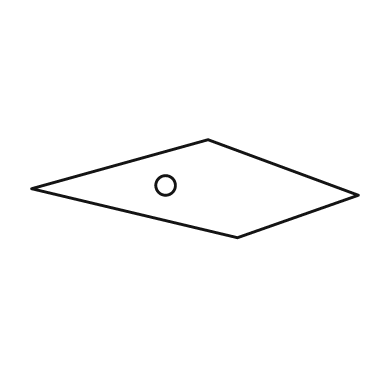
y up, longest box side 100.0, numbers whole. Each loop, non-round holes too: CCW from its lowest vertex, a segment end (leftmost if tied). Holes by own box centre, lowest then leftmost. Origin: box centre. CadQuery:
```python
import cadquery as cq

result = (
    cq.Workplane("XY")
    .moveTo(13.0, -15.0)
    .lineTo(50.0, -2.0)
    .lineTo(4.0, 15.0)
    .lineTo(-50.0, 0.0)
    .close()
    .moveTo(-9.0, 1.0)
    .circle(3.0)
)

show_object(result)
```